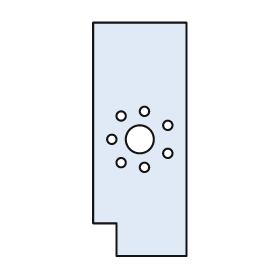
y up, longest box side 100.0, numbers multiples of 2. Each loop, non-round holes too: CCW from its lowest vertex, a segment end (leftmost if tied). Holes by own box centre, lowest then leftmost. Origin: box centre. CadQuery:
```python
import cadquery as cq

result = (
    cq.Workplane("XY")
    .moveTo(-10.0, -50.0)
    .lineTo(20.0, -50.0)
    .lineTo(20.0, 50.0)
    .lineTo(-20.0, 50.0)
    .lineTo(-20.0, -36.0)
    .lineTo(-10.0, -36.0)
    .close()
    .moveTo(2.0, -12.0)
    .circle(2.0)
    .moveTo(-8.0, -10.0)
    .circle(2.0)
    .moveTo(12.0, -6.0)
    .circle(2.0)
    .moveTo(-12.0, 0.0)
    .circle(2.0)
    .moveTo(0.0, 0.0)
    .circle(6.0)
    .moveTo(12.0, 6.0)
    .circle(2.0)
    .moveTo(-8.0, 10.0)
    .circle(2.0)
    .moveTo(2.0, 12.0)
    .circle(2.0)
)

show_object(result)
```